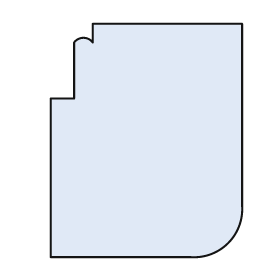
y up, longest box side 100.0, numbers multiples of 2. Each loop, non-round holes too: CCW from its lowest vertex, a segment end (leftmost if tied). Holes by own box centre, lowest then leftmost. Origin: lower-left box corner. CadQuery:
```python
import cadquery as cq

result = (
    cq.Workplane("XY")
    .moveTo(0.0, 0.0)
    .lineTo(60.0, 0.0)
    .threePointArc((76.0, 6.0), (82.0, 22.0))
    .lineTo(82.0, 100.0)
    .lineTo(18.0, 100.0)
    .lineTo(18.0, 92.0)
    .threePointArc((14.0, 94.0), (10.0, 92.0))
    .lineTo(10.0, 68.0)
    .lineTo(0.0, 68.0)
    .close()
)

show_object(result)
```